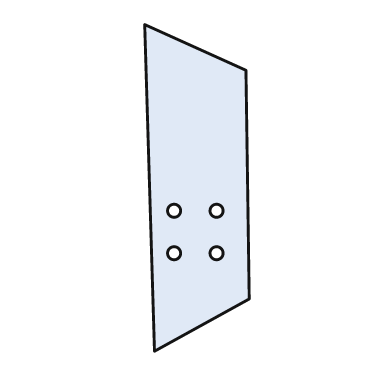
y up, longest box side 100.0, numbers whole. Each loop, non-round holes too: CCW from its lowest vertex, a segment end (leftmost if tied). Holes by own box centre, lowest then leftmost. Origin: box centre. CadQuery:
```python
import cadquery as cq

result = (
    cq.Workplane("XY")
    .moveTo(-13.0, -50.0)
    .lineTo(16.0, -34.0)
    .lineTo(15.0, 36.0)
    .lineTo(-16.0, 50.0)
    .close()
    .moveTo(-7.0, -20.0)
    .circle(2.0)
    .moveTo(6.0, -20.0)
    .circle(2.0)
    .moveTo(-7.0, -7.0)
    .circle(2.0)
    .moveTo(6.0, -7.0)
    .circle(2.0)
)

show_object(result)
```